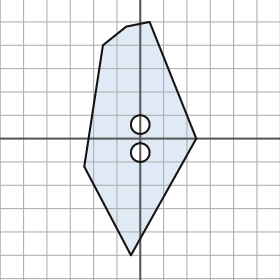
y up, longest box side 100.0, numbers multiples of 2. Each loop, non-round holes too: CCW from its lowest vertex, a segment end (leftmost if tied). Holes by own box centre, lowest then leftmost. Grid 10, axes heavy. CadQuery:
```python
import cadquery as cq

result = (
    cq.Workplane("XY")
    .moveTo(-4.0, -50.0)
    .lineTo(24.0, 0.0)
    .lineTo(4.0, 50.0)
    .lineTo(-6.0, 48.0)
    .lineTo(-16.0, 40.0)
    .lineTo(-24.0, -12.0)
    .close()
    .moveTo(0.0, -6.0)
    .circle(4.0)
    .moveTo(0.0, 6.0)
    .circle(4.0)
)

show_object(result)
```